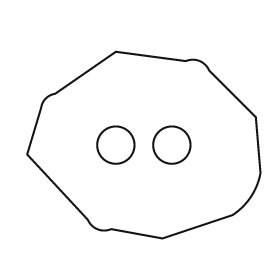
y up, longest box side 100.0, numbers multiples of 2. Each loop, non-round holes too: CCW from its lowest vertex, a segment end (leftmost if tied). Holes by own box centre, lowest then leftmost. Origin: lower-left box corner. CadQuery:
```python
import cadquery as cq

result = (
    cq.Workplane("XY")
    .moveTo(58.0, 0.0)
    .lineTo(88.0, 10.0)
    .threePointArc((96.0, 18.0), (100.0, 28.0))
    .lineTo(98.0, 52.0)
    .lineTo(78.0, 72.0)
    .threePointArc((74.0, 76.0), (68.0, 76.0))
    .lineTo(38.0, 80.0)
    .lineTo(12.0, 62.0)
    .threePointArc((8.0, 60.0), (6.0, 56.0))
    .lineTo(0.0, 36.0)
    .lineTo(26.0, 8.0)
    .threePointArc((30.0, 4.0), (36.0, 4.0))
    .close()
    .moveTo(38.0, 40.0)
    .circle(8.0)
    .moveTo(62.0, 40.0)
    .circle(8.0)
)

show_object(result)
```